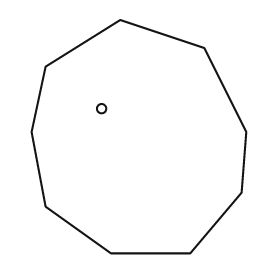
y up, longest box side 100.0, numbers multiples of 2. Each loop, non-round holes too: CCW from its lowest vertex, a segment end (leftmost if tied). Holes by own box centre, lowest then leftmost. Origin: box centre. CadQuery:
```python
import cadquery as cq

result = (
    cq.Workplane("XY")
    .moveTo(-12.0, -50.0)
    .lineTo(22.0, -50.0)
    .lineTo(44.0, -24.0)
    .lineTo(46.0, 2.0)
    .lineTo(28.0, 38.0)
    .lineTo(-8.0, 50.0)
    .lineTo(-40.0, 30.0)
    .lineTo(-46.0, 2.0)
    .lineTo(-40.0, -30.0)
    .close()
    .moveTo(-16.0, 12.0)
    .circle(2.0)
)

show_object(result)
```